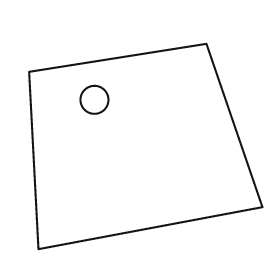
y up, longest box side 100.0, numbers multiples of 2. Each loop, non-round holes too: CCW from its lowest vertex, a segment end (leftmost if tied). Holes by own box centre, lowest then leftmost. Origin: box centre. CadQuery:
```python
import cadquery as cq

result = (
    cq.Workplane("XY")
    .moveTo(-46.0, -44.0)
    .lineTo(50.0, -26.0)
    .lineTo(26.0, 44.0)
    .lineTo(-50.0, 32.0)
    .close()
    .moveTo(-22.0, 20.0)
    .circle(6.0)
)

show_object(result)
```